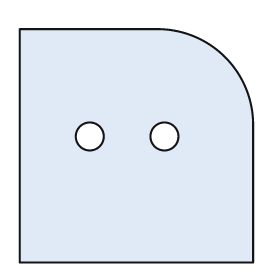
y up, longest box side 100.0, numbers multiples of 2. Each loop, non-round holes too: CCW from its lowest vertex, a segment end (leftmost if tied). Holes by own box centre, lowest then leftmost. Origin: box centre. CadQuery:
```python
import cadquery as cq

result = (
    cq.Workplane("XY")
    .moveTo(-50.0, -50.0)
    .lineTo(50.0, -50.0)
    .lineTo(50.0, 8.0)
    .threePointArc((38.0, 38.0), (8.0, 50.0))
    .lineTo(-50.0, 50.0)
    .close()
    .moveTo(-20.0, 4.0)
    .circle(6.0)
    .moveTo(12.0, 4.0)
    .circle(6.0)
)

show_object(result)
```